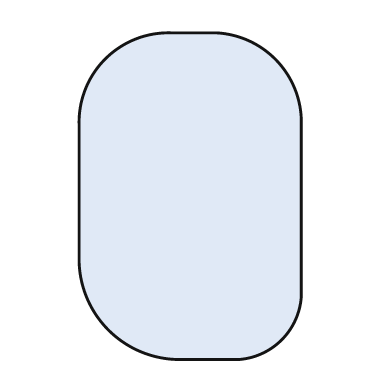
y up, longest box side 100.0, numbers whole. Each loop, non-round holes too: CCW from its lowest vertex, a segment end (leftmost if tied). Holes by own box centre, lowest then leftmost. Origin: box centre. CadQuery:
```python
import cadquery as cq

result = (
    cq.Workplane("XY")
    .moveTo(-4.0, -50.0)
    .lineTo(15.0, -50.0)
    .threePointArc((28.0, -44.0), (34.0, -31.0))
    .lineTo(34.0, 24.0)
    .threePointArc((26.0, 42.0), (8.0, 50.0))
    .lineTo(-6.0, 50.0)
    .threePointArc((-26.0, 42.0), (-34.0, 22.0))
    .lineTo(-34.0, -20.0)
    .threePointArc((-25.0, -41.0), (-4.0, -50.0))
    .close()
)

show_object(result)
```